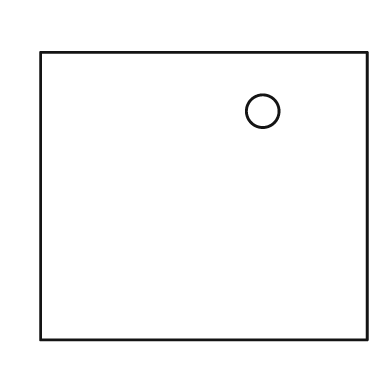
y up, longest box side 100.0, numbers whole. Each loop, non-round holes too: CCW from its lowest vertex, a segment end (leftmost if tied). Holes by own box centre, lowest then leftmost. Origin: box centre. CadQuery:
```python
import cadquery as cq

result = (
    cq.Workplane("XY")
    .moveTo(-50.0, -44.0)
    .lineTo(50.0, -44.0)
    .lineTo(50.0, 44.0)
    .lineTo(-50.0, 44.0)
    .close()
    .moveTo(18.0, 26.0)
    .circle(5.0)
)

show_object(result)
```